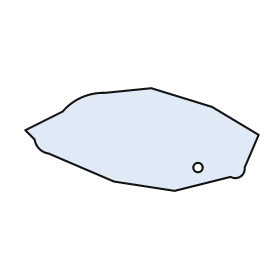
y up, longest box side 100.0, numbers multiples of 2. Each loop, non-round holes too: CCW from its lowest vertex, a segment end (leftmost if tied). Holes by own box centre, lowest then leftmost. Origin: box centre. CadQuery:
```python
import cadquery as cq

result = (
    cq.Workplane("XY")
    .moveTo(14.0, -22.0)
    .lineTo(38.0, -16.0)
    .threePointArc((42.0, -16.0), (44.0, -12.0))
    .lineTo(50.0, 2.0)
    .lineTo(30.0, 14.0)
    .lineTo(4.0, 22.0)
    .lineTo(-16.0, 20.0)
    .threePointArc((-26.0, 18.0), (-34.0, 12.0))
    .lineTo(-50.0, 4.0)
    .lineTo(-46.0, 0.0)
    .threePointArc((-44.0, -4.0), (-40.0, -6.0))
    .lineTo(-12.0, -18.0)
    .close()
    .moveTo(24.0, -12.0)
    .circle(2.0)
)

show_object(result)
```